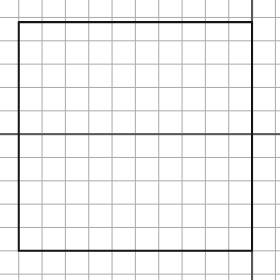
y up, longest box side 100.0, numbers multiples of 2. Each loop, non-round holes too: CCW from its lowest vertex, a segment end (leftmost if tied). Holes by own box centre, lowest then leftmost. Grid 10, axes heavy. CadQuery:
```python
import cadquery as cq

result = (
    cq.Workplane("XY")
    .moveTo(-100.0, -50.0)
    .lineTo(0.0, -50.0)
    .lineTo(0.0, 48.0)
    .lineTo(-100.0, 48.0)
    .close()
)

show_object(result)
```